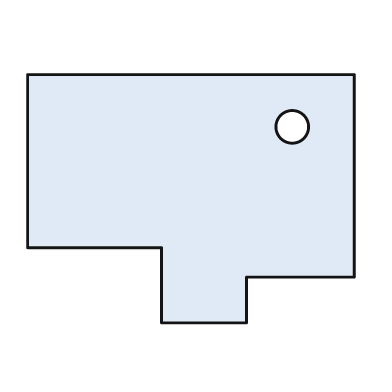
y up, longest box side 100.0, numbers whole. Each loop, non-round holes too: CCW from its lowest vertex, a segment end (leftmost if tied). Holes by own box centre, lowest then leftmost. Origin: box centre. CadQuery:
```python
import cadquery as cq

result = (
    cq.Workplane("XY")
    .moveTo(-9.0, -38.0)
    .lineTo(17.0, -38.0)
    .lineTo(17.0, -24.0)
    .lineTo(50.0, -24.0)
    .lineTo(50.0, 38.0)
    .lineTo(-50.0, 38.0)
    .lineTo(-50.0, -15.0)
    .lineTo(-9.0, -15.0)
    .close()
    .moveTo(31.0, 22.0)
    .circle(5.0)
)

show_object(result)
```